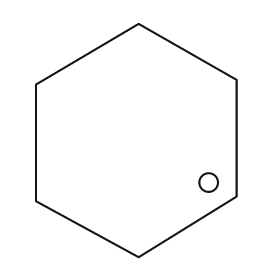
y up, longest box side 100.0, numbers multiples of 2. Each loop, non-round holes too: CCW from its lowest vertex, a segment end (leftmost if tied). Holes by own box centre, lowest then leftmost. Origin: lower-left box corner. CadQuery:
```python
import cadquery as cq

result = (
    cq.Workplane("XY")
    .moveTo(44.0, 0.0)
    .lineTo(86.0, 26.0)
    .lineTo(86.0, 76.0)
    .lineTo(44.0, 100.0)
    .lineTo(0.0, 74.0)
    .lineTo(0.0, 24.0)
    .close()
    .moveTo(74.0, 32.0)
    .circle(4.0)
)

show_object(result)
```